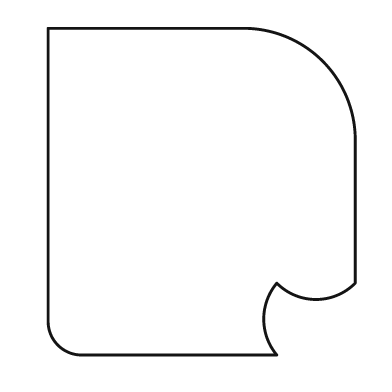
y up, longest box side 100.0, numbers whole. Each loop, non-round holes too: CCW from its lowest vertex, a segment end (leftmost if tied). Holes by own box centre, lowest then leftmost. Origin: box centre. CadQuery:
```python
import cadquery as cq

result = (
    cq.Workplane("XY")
    .moveTo(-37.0, -50.0)
    .lineTo(23.0, -50.0)
    .threePointArc((19.0, -39.0), (23.0, -28.0))
    .threePointArc((35.0, -33.0), (47.0, -28.0))
    .lineTo(47.0, 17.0)
    .threePointArc((37.0, 40.0), (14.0, 50.0))
    .lineTo(-47.0, 50.0)
    .lineTo(-47.0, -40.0)
    .threePointArc((-44.0, -47.0), (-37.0, -50.0))
    .close()
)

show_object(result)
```